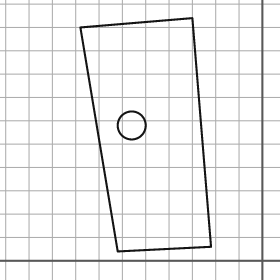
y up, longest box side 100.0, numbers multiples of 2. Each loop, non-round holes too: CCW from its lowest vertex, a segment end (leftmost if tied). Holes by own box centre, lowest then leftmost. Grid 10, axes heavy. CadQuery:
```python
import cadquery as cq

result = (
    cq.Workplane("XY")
    .moveTo(-62.0, 4.0)
    .lineTo(-22.0, 6.0)
    .lineTo(-30.0, 104.0)
    .lineTo(-78.0, 100.0)
    .close()
    .moveTo(-56.0, 58.0)
    .circle(6.0)
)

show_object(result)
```